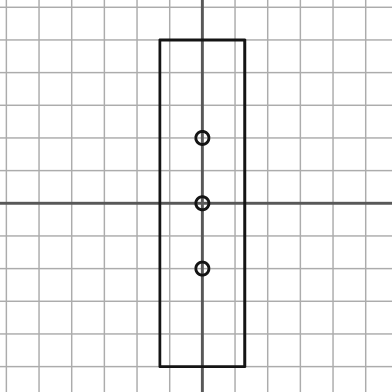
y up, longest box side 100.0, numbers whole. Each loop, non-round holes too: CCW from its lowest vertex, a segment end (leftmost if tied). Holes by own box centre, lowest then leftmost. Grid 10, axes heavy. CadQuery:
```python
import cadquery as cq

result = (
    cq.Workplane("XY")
    .moveTo(-13.0, -50.0)
    .lineTo(13.0, -50.0)
    .lineTo(13.0, 50.0)
    .lineTo(-13.0, 50.0)
    .close()
    .moveTo(0.0, -20.0)
    .circle(2.0)
    .moveTo(0.0, 0.0)
    .circle(2.0)
    .moveTo(0.0, 20.0)
    .circle(2.0)
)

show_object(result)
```